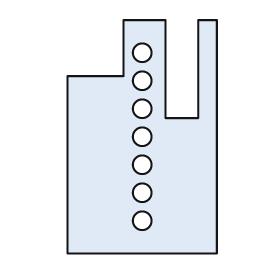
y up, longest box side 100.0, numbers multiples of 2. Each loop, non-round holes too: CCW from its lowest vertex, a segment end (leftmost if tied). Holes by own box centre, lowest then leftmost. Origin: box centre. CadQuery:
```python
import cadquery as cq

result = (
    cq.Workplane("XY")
    .moveTo(-32.0, -50.0)
    .lineTo(32.0, -50.0)
    .lineTo(32.0, 50.0)
    .lineTo(24.0, 50.0)
    .lineTo(24.0, 8.0)
    .lineTo(10.0, 8.0)
    .lineTo(10.0, 50.0)
    .lineTo(-8.0, 50.0)
    .lineTo(-8.0, 26.0)
    .lineTo(-32.0, 26.0)
    .close()
    .moveTo(0.0, -36.0)
    .circle(4.0)
    .moveTo(0.0, -24.0)
    .circle(4.0)
    .moveTo(0.0, -12.0)
    .circle(4.0)
    .moveTo(0.0, 0.0)
    .circle(4.0)
    .moveTo(0.0, 12.0)
    .circle(4.0)
    .moveTo(0.0, 24.0)
    .circle(4.0)
    .moveTo(0.0, 36.0)
    .circle(4.0)
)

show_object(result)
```